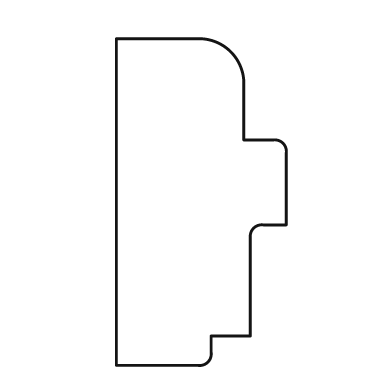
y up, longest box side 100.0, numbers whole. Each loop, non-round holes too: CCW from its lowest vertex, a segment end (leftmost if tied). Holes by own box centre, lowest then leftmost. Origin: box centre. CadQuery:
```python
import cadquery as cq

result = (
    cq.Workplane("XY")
    .moveTo(-26.0, -50.0)
    .lineTo(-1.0, -50.0)
    .threePointArc((2.0, -49.0), (3.0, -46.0))
    .lineTo(3.0, -41.0)
    .lineTo(15.0, -41.0)
    .lineTo(15.0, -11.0)
    .threePointArc((16.0, -8.0), (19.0, -7.0))
    .lineTo(26.0, -7.0)
    .lineTo(26.0, 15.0)
    .threePointArc((25.0, 18.0), (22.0, 19.0))
    .lineTo(13.0, 19.0)
    .lineTo(13.0, 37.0)
    .threePointArc((9.0, 46.0), (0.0, 50.0))
    .lineTo(-26.0, 50.0)
    .close()
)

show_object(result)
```